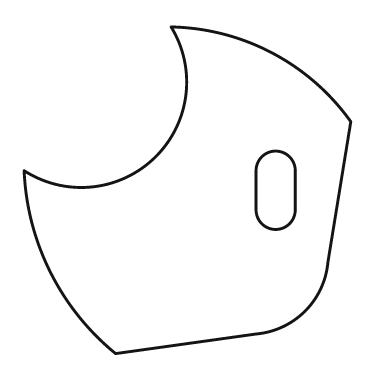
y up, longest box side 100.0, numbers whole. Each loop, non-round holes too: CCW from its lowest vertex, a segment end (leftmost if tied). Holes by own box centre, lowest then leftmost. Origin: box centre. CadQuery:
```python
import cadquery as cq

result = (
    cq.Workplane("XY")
    .moveTo(-22.0, -50.0)
    .lineTo(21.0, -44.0)
    .threePointArc((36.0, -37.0), (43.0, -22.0))
    .lineTo(50.0, 21.0)
    .threePointArc((26.0, 42.0), (-5.0, 50.0))
    .threePointArc((-10.0, 10.0), (-50.0, 6.0))
    .threePointArc((-42.0, -25.0), (-22.0, -50.0))
    .close()
    .moveTo(21.0, -6.0)
    .threePointArc((27.0, -12.0), (33.0, -6.0))
    .lineTo(33.0, 6.0)
    .threePointArc((27.0, 12.0), (21.0, 6.0))
    .close()
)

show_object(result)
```